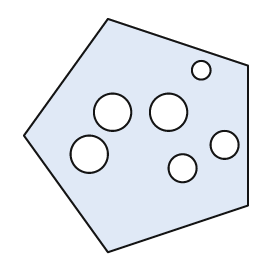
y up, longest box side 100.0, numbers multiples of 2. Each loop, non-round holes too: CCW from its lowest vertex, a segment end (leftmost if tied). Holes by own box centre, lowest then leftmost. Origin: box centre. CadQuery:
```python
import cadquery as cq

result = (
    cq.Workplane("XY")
    .moveTo(-12.0, -50.0)
    .lineTo(48.0, -30.0)
    .lineTo(48.0, 30.0)
    .lineTo(-12.0, 50.0)
    .lineTo(-48.0, 0.0)
    .close()
    .moveTo(20.0, -14.0)
    .circle(6.0)
    .moveTo(-20.0, -8.0)
    .circle(8.0)
    .moveTo(38.0, -4.0)
    .circle(6.0)
    .moveTo(-10.0, 10.0)
    .circle(8.0)
    .moveTo(14.0, 10.0)
    .circle(8.0)
    .moveTo(28.0, 28.0)
    .circle(4.0)
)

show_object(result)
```